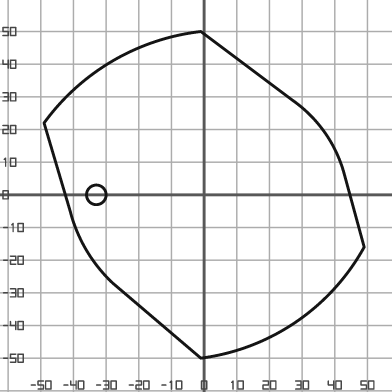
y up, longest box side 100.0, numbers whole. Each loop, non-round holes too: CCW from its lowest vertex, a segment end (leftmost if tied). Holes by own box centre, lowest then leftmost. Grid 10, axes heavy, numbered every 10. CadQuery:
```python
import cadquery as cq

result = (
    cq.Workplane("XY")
    .moveTo(-1.0, -50.0)
    .threePointArc((28.0, -39.0), (49.0, -16.0))
    .lineTo(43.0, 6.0)
    .threePointArc((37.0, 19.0), (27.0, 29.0))
    .lineTo(-1.0, 50.0)
    .threePointArc((-28.0, 41.0), (-49.0, 22.0))
    .lineTo(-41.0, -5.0)
    .threePointArc((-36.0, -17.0), (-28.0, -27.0))
    .close()
    .moveTo(-33.0, 0.0)
    .circle(3.0)
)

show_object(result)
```